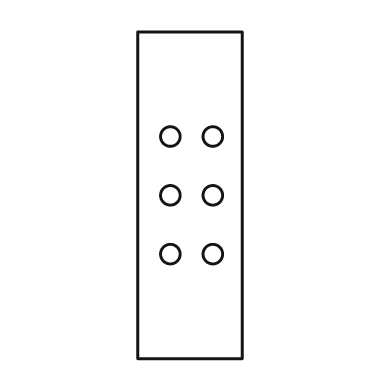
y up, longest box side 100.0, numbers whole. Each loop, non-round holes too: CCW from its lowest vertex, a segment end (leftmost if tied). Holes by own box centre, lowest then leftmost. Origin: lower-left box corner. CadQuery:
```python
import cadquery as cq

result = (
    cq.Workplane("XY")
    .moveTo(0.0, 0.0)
    .lineTo(32.0, 0.0)
    .lineTo(32.0, 100.0)
    .lineTo(0.0, 100.0)
    .close()
    .moveTo(10.0, 32.0)
    .circle(3.0)
    .moveTo(23.0, 32.0)
    .circle(3.0)
    .moveTo(10.0, 50.0)
    .circle(3.0)
    .moveTo(23.0, 50.0)
    .circle(3.0)
    .moveTo(10.0, 68.0)
    .circle(3.0)
    .moveTo(23.0, 68.0)
    .circle(3.0)
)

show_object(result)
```